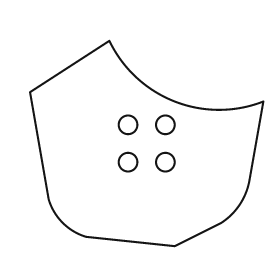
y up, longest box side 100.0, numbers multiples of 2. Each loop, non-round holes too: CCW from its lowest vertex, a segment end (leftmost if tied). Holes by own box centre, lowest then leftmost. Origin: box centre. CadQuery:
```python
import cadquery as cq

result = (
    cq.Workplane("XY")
    .moveTo(12.0, -44.0)
    .lineTo(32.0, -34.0)
    .threePointArc((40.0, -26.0), (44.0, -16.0))
    .lineTo(50.0, 18.0)
    .threePointArc((12.0, 18.0), (-16.0, 44.0))
    .lineTo(-50.0, 22.0)
    .lineTo(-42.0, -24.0)
    .threePointArc((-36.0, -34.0), (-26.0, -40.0))
    .close()
    .moveTo(-8.0, -8.0)
    .circle(4.0)
    .moveTo(8.0, -8.0)
    .circle(4.0)
    .moveTo(-8.0, 8.0)
    .circle(4.0)
    .moveTo(8.0, 8.0)
    .circle(4.0)
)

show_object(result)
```